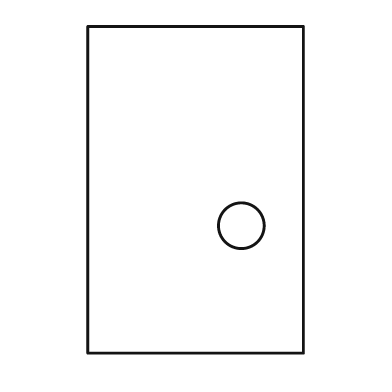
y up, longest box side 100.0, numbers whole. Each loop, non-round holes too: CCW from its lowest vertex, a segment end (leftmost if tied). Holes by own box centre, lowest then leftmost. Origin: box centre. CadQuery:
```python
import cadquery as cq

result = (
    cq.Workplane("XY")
    .moveTo(-33.0, -50.0)
    .lineTo(33.0, -50.0)
    .lineTo(33.0, 50.0)
    .lineTo(-33.0, 50.0)
    .close()
    .moveTo(14.0, -11.0)
    .circle(7.0)
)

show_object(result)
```